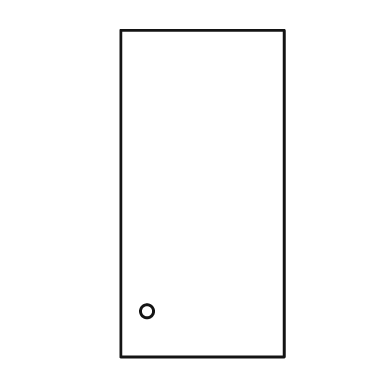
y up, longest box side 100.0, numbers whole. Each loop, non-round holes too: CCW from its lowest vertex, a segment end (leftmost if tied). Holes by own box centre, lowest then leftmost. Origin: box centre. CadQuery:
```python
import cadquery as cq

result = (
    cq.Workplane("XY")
    .moveTo(-25.0, -50.0)
    .lineTo(25.0, -50.0)
    .lineTo(25.0, 50.0)
    .lineTo(-25.0, 50.0)
    .close()
    .moveTo(-17.0, -36.0)
    .circle(2.0)
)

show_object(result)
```